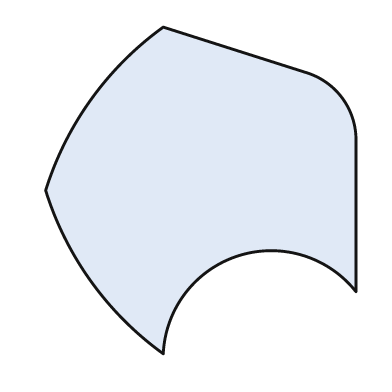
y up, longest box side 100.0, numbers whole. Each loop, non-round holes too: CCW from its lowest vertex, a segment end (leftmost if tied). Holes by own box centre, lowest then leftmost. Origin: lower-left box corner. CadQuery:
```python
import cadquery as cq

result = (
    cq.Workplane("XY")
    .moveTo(36.0, 0.0)
    .threePointArc((59.0, 30.0), (95.0, 19.0))
    .lineTo(95.0, 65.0)
    .threePointArc((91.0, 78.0), (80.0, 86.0))
    .lineTo(36.0, 100.0)
    .threePointArc((14.0, 78.0), (0.0, 50.0))
    .threePointArc((14.0, 22.0), (36.0, 0.0))
    .close()
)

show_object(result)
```